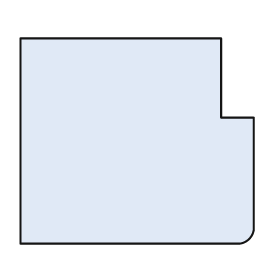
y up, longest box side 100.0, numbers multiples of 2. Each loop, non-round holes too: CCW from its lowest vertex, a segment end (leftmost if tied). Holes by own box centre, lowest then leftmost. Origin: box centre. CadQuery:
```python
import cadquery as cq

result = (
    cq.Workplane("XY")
    .moveTo(-50.0, -44.0)
    .lineTo(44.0, -44.0)
    .threePointArc((48.0, -42.0), (50.0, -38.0))
    .lineTo(50.0, 10.0)
    .lineTo(36.0, 10.0)
    .lineTo(36.0, 44.0)
    .lineTo(-50.0, 44.0)
    .close()
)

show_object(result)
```